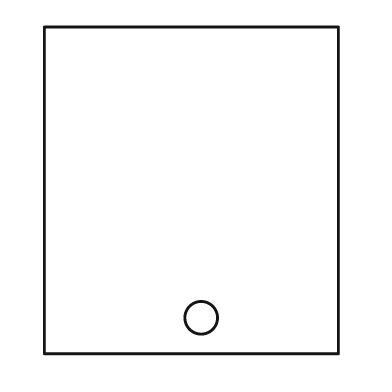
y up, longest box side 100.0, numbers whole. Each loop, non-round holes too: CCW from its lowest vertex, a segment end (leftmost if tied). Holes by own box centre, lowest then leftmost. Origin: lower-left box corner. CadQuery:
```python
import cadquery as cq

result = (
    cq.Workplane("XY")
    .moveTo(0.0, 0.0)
    .lineTo(90.0, 0.0)
    .lineTo(90.0, 100.0)
    .lineTo(0.0, 100.0)
    .close()
    .moveTo(48.0, 11.0)
    .circle(5.0)
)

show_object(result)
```